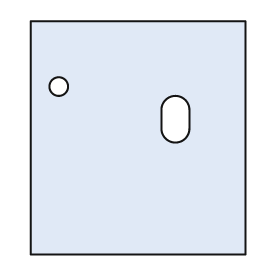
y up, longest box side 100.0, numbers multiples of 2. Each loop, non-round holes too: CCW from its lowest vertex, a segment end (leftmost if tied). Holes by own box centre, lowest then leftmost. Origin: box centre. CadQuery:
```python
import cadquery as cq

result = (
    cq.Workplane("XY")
    .moveTo(-46.0, -50.0)
    .lineTo(46.0, -50.0)
    .lineTo(46.0, 50.0)
    .lineTo(-46.0, 50.0)
    .close()
    .moveTo(10.0, 4.0)
    .threePointArc((16.0, -2.0), (22.0, 4.0))
    .lineTo(22.0, 12.0)
    .threePointArc((16.0, 18.0), (10.0, 12.0))
    .close()
    .moveTo(-34.0, 22.0)
    .circle(4.0)
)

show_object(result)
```